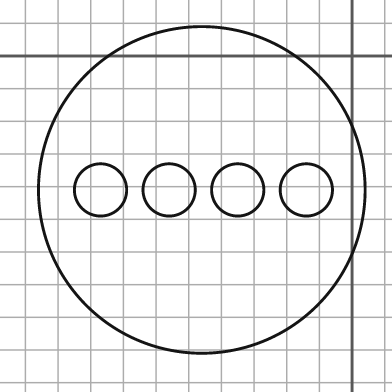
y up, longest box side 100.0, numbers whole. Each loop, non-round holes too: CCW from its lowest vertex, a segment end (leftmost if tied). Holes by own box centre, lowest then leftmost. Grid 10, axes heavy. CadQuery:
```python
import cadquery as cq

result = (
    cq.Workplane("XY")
    .moveTo(-46.0, -41.0)
    .circle(50.0)
    .moveTo(-77.0, -41.0)
    .circle(8.0)
    .moveTo(-56.0, -41.0)
    .circle(8.0)
    .moveTo(-35.0, -41.0)
    .circle(8.0)
    .moveTo(-14.0, -41.0)
    .circle(8.0)
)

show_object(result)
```